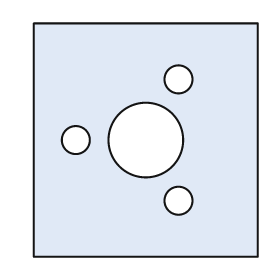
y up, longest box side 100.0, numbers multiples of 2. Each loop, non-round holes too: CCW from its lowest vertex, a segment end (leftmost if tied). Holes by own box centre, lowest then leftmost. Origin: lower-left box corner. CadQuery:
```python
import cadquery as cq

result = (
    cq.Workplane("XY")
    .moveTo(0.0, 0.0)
    .lineTo(96.0, 0.0)
    .lineTo(96.0, 100.0)
    .lineTo(0.0, 100.0)
    .close()
    .moveTo(62.0, 24.0)
    .circle(6.0)
    .moveTo(18.0, 50.0)
    .circle(6.0)
    .moveTo(48.0, 50.0)
    .circle(16.0)
    .moveTo(62.0, 76.0)
    .circle(6.0)
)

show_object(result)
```